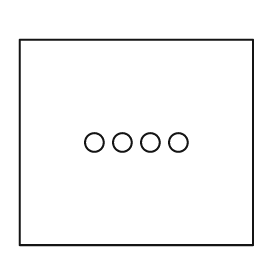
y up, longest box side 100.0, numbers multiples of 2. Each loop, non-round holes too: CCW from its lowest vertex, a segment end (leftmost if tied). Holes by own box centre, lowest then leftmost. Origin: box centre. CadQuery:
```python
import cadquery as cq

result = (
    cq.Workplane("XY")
    .moveTo(-50.0, -44.0)
    .lineTo(50.0, -44.0)
    .lineTo(50.0, 44.0)
    .lineTo(-50.0, 44.0)
    .close()
    .moveTo(-18.0, 0.0)
    .circle(4.0)
    .moveTo(-6.0, 0.0)
    .circle(4.0)
    .moveTo(6.0, 0.0)
    .circle(4.0)
    .moveTo(18.0, 0.0)
    .circle(4.0)
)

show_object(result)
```